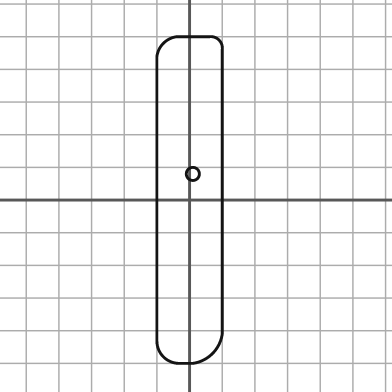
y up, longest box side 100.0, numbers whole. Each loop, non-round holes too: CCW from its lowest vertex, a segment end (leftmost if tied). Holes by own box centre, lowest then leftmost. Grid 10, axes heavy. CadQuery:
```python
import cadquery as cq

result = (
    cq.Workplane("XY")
    .moveTo(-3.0, -50.0)
    .lineTo(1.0, -50.0)
    .threePointArc((7.0, -47.0), (10.0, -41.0))
    .lineTo(10.0, 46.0)
    .threePointArc((9.0, 49.0), (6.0, 50.0))
    .lineTo(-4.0, 50.0)
    .threePointArc((-8.0, 48.0), (-10.0, 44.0))
    .lineTo(-10.0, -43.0)
    .threePointArc((-8.0, -48.0), (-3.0, -50.0))
    .close()
    .moveTo(1.0, 8.0)
    .circle(2.0)
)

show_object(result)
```